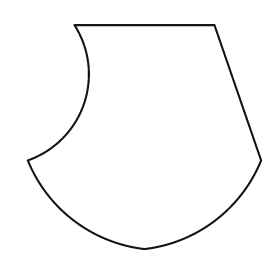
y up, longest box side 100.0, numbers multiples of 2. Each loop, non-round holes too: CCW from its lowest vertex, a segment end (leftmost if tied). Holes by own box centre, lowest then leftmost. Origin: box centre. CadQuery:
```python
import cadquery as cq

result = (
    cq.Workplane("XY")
    .moveTo(0.0, -48.0)
    .threePointArc((30.0, -36.0), (50.0, -10.0))
    .lineTo(30.0, 48.0)
    .lineTo(-30.0, 48.0)
    .threePointArc((-26.0, 14.0), (-50.0, -10.0))
    .threePointArc((-30.0, -36.0), (0.0, -48.0))
    .close()
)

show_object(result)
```